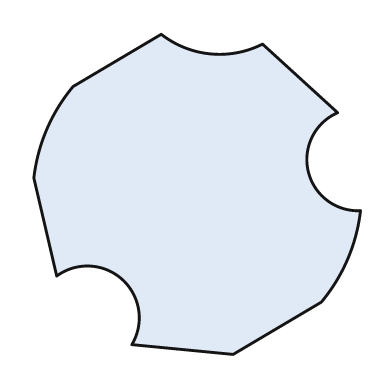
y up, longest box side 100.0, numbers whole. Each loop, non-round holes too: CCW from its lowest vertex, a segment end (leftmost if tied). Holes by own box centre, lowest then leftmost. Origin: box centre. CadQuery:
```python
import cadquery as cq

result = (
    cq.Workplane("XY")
    .moveTo(11.0, -49.0)
    .lineTo(38.0, -33.0)
    .threePointArc((46.0, -20.0), (50.0, -5.0))
    .threePointArc((34.0, 7.0), (43.0, 25.0))
    .lineTo(20.0, 46.0)
    .threePointArc((4.0, 43.0), (-11.0, 49.0))
    .lineTo(-38.0, 33.0)
    .threePointArc((-46.0, 20.0), (-50.0, 5.0))
    .lineTo(-43.0, -25.0)
    .threePointArc((-23.0, -26.0), (-20.0, -46.0))
    .close()
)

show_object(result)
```